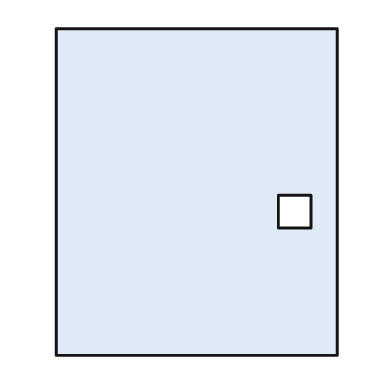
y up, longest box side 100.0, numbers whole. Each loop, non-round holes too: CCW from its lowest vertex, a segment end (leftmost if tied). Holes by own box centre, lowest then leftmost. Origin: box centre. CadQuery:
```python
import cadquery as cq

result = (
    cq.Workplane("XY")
    .moveTo(-43.0, -50.0)
    .lineTo(43.0, -50.0)
    .lineTo(43.0, 50.0)
    .lineTo(-43.0, 50.0)
    .close()
    .moveTo(25.0, -11.0)
    .lineTo(35.0, -11.0)
    .lineTo(35.0, -1.0)
    .lineTo(25.0, -1.0)
    .close()
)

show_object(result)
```